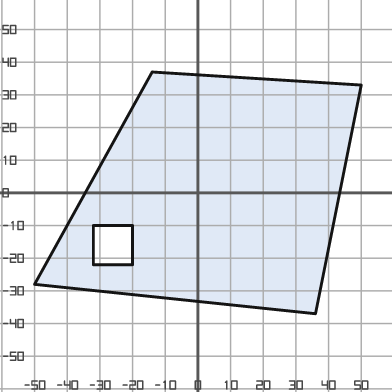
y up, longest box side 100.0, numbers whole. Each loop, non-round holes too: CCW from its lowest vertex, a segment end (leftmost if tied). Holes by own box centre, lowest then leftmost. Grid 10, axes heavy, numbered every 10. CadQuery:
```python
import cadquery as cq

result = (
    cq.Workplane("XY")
    .moveTo(36.0, -37.0)
    .lineTo(50.0, 33.0)
    .lineTo(-14.0, 37.0)
    .lineTo(-50.0, -28.0)
    .close()
    .moveTo(-32.0, -22.0)
    .lineTo(-20.0, -22.0)
    .lineTo(-20.0, -10.0)
    .lineTo(-32.0, -10.0)
    .close()
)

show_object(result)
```